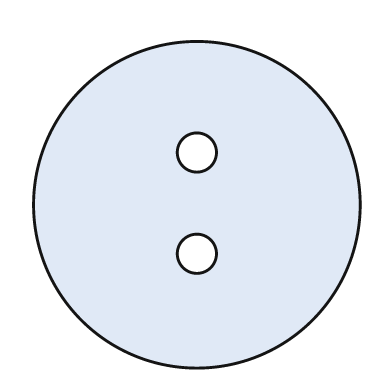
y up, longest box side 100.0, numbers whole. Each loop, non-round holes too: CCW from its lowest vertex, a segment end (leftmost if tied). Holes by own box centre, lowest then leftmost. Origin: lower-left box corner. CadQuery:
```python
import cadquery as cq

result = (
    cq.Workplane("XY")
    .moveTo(50.0, 50.0)
    .circle(50.0)
    .moveTo(50.0, 35.0)
    .circle(6.0)
    .moveTo(50.0, 66.0)
    .circle(6.0)
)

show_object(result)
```